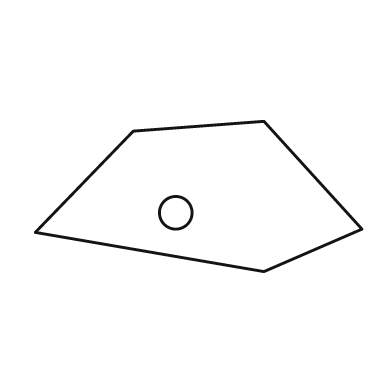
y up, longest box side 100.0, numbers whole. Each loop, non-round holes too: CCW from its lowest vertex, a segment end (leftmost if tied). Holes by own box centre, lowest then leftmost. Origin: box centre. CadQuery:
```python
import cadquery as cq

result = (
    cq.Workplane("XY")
    .moveTo(20.0, -23.0)
    .lineTo(50.0, -10.0)
    .lineTo(20.0, 23.0)
    .lineTo(-20.0, 20.0)
    .lineTo(-50.0, -11.0)
    .close()
    .moveTo(-7.0, -5.0)
    .circle(5.0)
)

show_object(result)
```